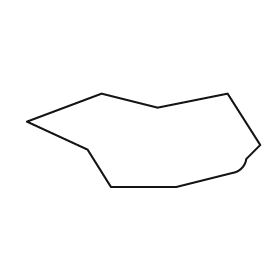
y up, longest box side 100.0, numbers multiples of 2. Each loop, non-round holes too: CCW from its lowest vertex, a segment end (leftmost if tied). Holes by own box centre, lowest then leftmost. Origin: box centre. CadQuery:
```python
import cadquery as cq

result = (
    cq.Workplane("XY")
    .moveTo(-14.0, -20.0)
    .lineTo(14.0, -20.0)
    .lineTo(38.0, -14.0)
    .threePointArc((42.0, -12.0), (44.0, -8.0))
    .lineTo(50.0, -2.0)
    .lineTo(36.0, 20.0)
    .lineTo(6.0, 14.0)
    .lineTo(-18.0, 20.0)
    .lineTo(-50.0, 8.0)
    .lineTo(-24.0, -4.0)
    .close()
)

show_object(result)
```